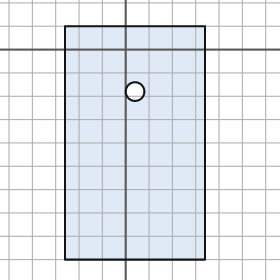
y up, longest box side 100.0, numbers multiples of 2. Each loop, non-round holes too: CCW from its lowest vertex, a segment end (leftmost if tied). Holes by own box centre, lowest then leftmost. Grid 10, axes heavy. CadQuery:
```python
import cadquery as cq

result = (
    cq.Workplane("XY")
    .moveTo(-26.0, -90.0)
    .lineTo(34.0, -90.0)
    .lineTo(34.0, 10.0)
    .lineTo(-26.0, 10.0)
    .close()
    .moveTo(4.0, -18.0)
    .circle(4.0)
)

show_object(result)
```